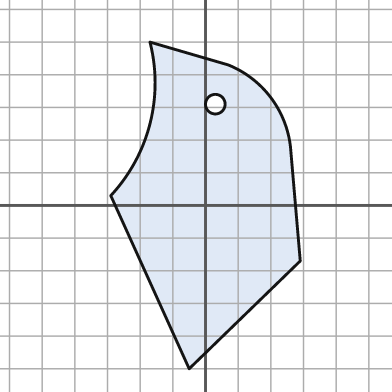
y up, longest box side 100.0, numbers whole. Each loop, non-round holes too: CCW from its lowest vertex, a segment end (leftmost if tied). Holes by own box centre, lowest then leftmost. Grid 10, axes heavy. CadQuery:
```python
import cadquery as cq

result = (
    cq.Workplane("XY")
    .moveTo(-5.0, -50.0)
    .lineTo(29.0, -17.0)
    .lineTo(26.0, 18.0)
    .threePointArc((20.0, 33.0), (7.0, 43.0))
    .lineTo(-17.0, 50.0)
    .threePointArc((-17.0, 25.0), (-29.0, 3.0))
    .close()
    .moveTo(3.0, 31.0)
    .circle(3.0)
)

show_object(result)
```